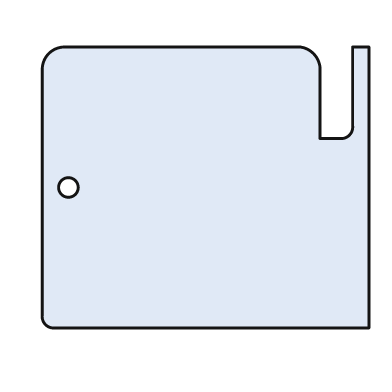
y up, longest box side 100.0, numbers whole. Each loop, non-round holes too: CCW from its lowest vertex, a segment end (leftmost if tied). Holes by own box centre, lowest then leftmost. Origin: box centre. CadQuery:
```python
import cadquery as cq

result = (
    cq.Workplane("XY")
    .moveTo(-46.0, -43.0)
    .lineTo(50.0, -43.0)
    .lineTo(50.0, 43.0)
    .lineTo(45.0, 43.0)
    .lineTo(45.0, 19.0)
    .threePointArc((44.0, 16.0), (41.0, 15.0))
    .lineTo(35.0, 15.0)
    .lineTo(35.0, 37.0)
    .threePointArc((33.0, 41.0), (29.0, 43.0))
    .lineTo(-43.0, 43.0)
    .threePointArc((-48.0, 41.0), (-50.0, 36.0))
    .lineTo(-50.0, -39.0)
    .threePointArc((-49.0, -42.0), (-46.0, -43.0))
    .close()
    .moveTo(-42.0, 0.0)
    .circle(3.0)
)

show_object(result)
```